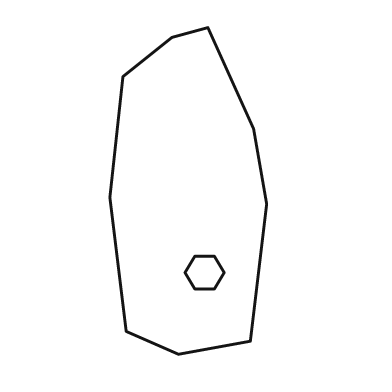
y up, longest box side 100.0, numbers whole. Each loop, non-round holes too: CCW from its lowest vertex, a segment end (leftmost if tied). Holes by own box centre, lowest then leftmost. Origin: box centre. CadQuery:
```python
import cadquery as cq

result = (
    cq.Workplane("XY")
    .moveTo(-3.0, -50.0)
    .lineTo(19.0, -46.0)
    .lineTo(24.0, -4.0)
    .lineTo(20.0, 19.0)
    .lineTo(6.0, 50.0)
    .lineTo(-5.0, 47.0)
    .lineTo(-20.0, 35.0)
    .lineTo(-24.0, -2.0)
    .lineTo(-19.0, -43.0)
    .close()
    .moveTo(2.0, -30.0)
    .lineTo(8.0, -30.0)
    .lineTo(11.0, -25.0)
    .lineTo(8.0, -20.0)
    .lineTo(2.0, -20.0)
    .lineTo(-1.0, -25.0)
    .close()
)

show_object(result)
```